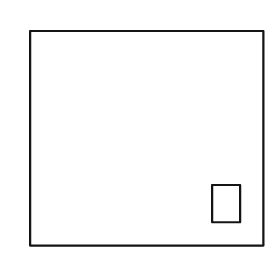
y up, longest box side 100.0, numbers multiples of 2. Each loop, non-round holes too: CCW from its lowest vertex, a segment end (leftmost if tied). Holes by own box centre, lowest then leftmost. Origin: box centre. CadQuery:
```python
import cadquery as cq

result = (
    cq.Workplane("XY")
    .moveTo(-50.0, -46.0)
    .lineTo(50.0, -46.0)
    .lineTo(50.0, 46.0)
    .lineTo(-50.0, 46.0)
    .close()
    .moveTo(28.0, -36.0)
    .lineTo(40.0, -36.0)
    .lineTo(40.0, -20.0)
    .lineTo(28.0, -20.0)
    .close()
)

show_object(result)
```